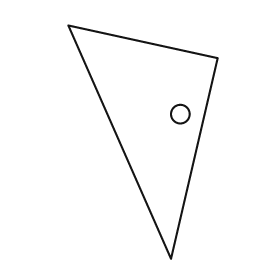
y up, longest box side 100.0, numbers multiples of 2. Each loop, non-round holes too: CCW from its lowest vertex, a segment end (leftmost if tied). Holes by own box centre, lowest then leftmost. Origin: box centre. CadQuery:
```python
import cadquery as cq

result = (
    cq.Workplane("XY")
    .moveTo(12.0, -50.0)
    .lineTo(32.0, 36.0)
    .lineTo(-32.0, 50.0)
    .close()
    .moveTo(16.0, 12.0)
    .circle(4.0)
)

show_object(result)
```